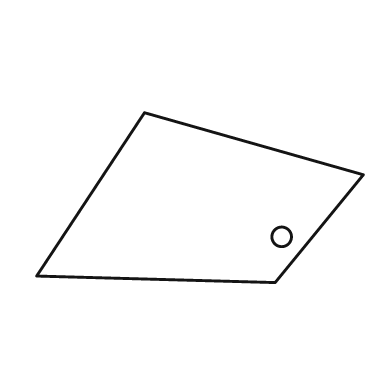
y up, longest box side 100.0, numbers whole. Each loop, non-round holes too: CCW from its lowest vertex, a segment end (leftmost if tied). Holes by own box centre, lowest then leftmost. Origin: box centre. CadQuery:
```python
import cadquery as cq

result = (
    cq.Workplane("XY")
    .moveTo(23.0, -26.0)
    .lineTo(50.0, 7.0)
    .lineTo(-17.0, 26.0)
    .lineTo(-50.0, -24.0)
    .close()
    .moveTo(25.0, -12.0)
    .circle(3.0)
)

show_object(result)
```